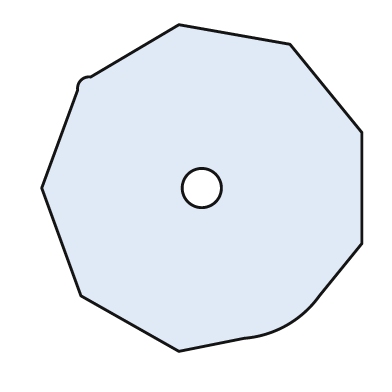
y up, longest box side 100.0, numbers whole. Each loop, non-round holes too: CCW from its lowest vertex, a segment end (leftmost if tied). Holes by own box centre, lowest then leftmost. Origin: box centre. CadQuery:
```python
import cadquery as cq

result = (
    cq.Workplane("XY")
    .moveTo(-7.0, -50.0)
    .lineTo(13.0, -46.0)
    .threePointArc((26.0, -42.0), (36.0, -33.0))
    .lineTo(49.0, -17.0)
    .lineTo(49.0, 17.0)
    .lineTo(27.0, 44.0)
    .lineTo(-7.0, 50.0)
    .lineTo(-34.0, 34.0)
    .threePointArc((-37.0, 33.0), (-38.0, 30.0))
    .lineTo(-49.0, 0.0)
    .lineTo(-37.0, -33.0)
    .close()
    .moveTo(0.0, 0.0)
    .circle(6.0)
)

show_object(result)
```